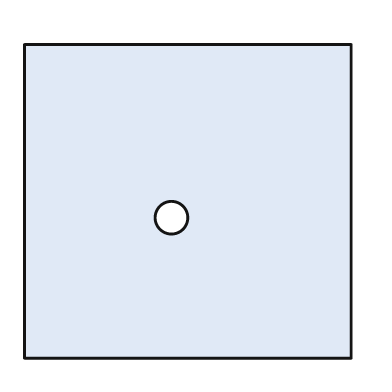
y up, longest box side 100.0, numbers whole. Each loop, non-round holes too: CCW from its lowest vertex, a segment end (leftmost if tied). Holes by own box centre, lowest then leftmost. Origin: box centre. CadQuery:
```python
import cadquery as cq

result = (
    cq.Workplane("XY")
    .moveTo(-50.0, -48.0)
    .lineTo(50.0, -48.0)
    .lineTo(50.0, 48.0)
    .lineTo(-50.0, 48.0)
    .close()
    .moveTo(-5.0, -5.0)
    .circle(5.0)
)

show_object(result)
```